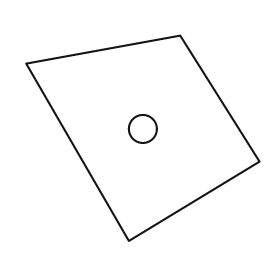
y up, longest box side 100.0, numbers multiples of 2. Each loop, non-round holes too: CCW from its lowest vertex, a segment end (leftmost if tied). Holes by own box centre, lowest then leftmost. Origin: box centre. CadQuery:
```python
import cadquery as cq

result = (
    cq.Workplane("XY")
    .moveTo(-6.0, -44.0)
    .lineTo(50.0, -10.0)
    .lineTo(16.0, 44.0)
    .lineTo(-50.0, 32.0)
    .close()
    .moveTo(0.0, 4.0)
    .circle(6.0)
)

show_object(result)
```